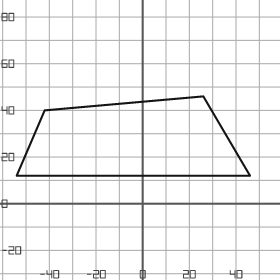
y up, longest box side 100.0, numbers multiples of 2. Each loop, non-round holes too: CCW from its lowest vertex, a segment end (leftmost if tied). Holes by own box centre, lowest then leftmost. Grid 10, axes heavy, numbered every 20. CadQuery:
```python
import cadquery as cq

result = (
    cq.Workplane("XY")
    .moveTo(-54.0, 12.0)
    .lineTo(46.0, 12.0)
    .lineTo(26.0, 46.0)
    .lineTo(-42.0, 40.0)
    .close()
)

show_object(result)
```